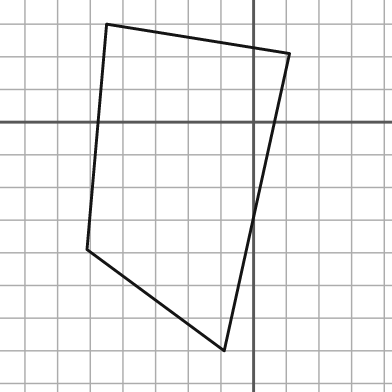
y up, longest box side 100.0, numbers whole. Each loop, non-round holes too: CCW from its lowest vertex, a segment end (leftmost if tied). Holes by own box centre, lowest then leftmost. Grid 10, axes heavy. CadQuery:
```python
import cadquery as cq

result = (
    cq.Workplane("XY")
    .moveTo(-9.0, -70.0)
    .lineTo(11.0, 21.0)
    .lineTo(-45.0, 30.0)
    .lineTo(-51.0, -39.0)
    .close()
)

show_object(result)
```